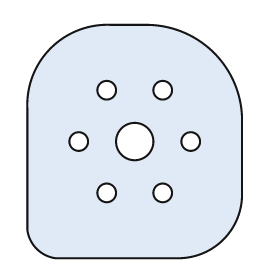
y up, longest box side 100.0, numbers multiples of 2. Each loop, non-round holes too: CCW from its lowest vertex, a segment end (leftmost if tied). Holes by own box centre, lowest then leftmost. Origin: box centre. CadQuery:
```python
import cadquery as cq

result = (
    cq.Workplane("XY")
    .moveTo(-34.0, -50.0)
    .lineTo(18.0, -50.0)
    .threePointArc((38.0, -42.0), (46.0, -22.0))
    .lineTo(46.0, 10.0)
    .threePointArc((34.0, 38.0), (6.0, 50.0))
    .lineTo(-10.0, 50.0)
    .threePointArc((-36.0, 40.0), (-46.0, 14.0))
    .lineTo(-46.0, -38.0)
    .threePointArc((-42.0, -46.0), (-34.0, -50.0))
    .close()
    .moveTo(-12.0, -22.0)
    .circle(4.0)
    .moveTo(12.0, -22.0)
    .circle(4.0)
    .moveTo(-24.0, 0.0)
    .circle(4.0)
    .moveTo(0.0, 0.0)
    .circle(8.0)
    .moveTo(24.0, 0.0)
    .circle(4.0)
    .moveTo(-12.0, 22.0)
    .circle(4.0)
    .moveTo(12.0, 22.0)
    .circle(4.0)
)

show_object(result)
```